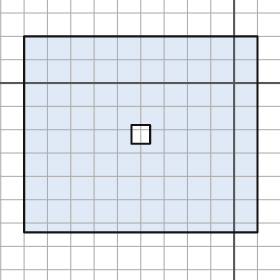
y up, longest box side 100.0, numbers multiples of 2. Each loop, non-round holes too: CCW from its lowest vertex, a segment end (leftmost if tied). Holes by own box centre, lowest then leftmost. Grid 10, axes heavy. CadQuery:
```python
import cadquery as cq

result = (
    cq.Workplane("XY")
    .moveTo(-90.0, -64.0)
    .lineTo(10.0, -64.0)
    .lineTo(10.0, 20.0)
    .lineTo(-90.0, 20.0)
    .close()
    .moveTo(-44.0, -26.0)
    .lineTo(-36.0, -26.0)
    .lineTo(-36.0, -18.0)
    .lineTo(-44.0, -18.0)
    .close()
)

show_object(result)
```